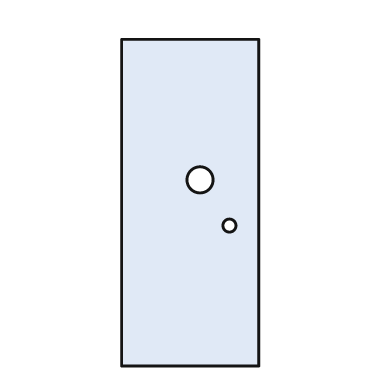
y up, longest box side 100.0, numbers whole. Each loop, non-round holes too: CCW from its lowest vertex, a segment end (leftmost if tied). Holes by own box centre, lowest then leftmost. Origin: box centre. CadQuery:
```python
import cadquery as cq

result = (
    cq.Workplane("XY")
    .moveTo(-21.0, -50.0)
    .lineTo(21.0, -50.0)
    .lineTo(21.0, 50.0)
    .lineTo(-21.0, 50.0)
    .close()
    .moveTo(12.0, -7.0)
    .circle(2.0)
    .moveTo(3.0, 7.0)
    .circle(4.0)
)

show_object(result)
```